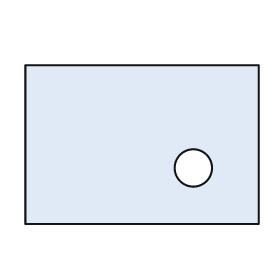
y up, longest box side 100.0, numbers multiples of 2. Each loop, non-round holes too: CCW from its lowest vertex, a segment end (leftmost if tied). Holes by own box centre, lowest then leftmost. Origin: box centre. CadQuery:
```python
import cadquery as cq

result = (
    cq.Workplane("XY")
    .moveTo(-50.0, -34.0)
    .lineTo(50.0, -34.0)
    .lineTo(50.0, 34.0)
    .lineTo(-50.0, 34.0)
    .close()
    .moveTo(22.0, -10.0)
    .circle(8.0)
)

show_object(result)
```